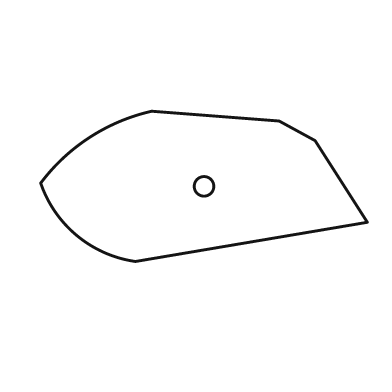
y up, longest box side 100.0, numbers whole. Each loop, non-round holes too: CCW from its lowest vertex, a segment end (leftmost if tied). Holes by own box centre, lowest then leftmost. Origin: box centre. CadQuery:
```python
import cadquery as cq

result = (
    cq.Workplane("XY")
    .moveTo(-21.0, -23.0)
    .lineTo(50.0, -11.0)
    .lineTo(34.0, 14.0)
    .lineTo(23.0, 20.0)
    .lineTo(-16.0, 23.0)
    .threePointArc((-35.0, 15.0), (-50.0, 1.0))
    .threePointArc((-39.0, -15.0), (-21.0, -23.0))
    .close()
    .moveTo(0.0, 0.0)
    .circle(3.0)
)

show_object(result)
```